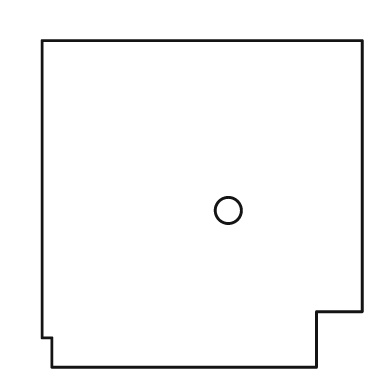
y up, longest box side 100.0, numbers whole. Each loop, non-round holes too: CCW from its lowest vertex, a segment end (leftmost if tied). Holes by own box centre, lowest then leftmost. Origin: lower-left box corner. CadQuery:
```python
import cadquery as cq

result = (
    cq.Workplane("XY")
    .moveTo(3.0, 0.0)
    .lineTo(84.0, 0.0)
    .lineTo(84.0, 17.0)
    .lineTo(98.0, 17.0)
    .lineTo(98.0, 100.0)
    .lineTo(0.0, 100.0)
    .lineTo(0.0, 9.0)
    .lineTo(3.0, 9.0)
    .close()
    .moveTo(57.0, 48.0)
    .circle(4.0)
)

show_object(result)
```